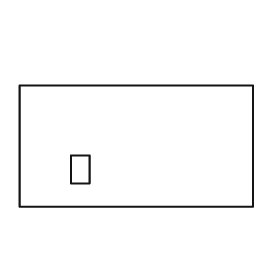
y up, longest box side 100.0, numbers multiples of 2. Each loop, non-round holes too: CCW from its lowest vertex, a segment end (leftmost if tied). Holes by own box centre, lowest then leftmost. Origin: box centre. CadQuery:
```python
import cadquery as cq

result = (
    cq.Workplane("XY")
    .moveTo(-50.0, -26.0)
    .lineTo(50.0, -26.0)
    .lineTo(50.0, 26.0)
    .lineTo(-50.0, 26.0)
    .close()
    .moveTo(-28.0, -16.0)
    .lineTo(-20.0, -16.0)
    .lineTo(-20.0, -4.0)
    .lineTo(-28.0, -4.0)
    .close()
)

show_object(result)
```